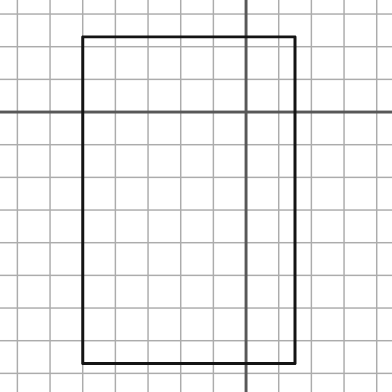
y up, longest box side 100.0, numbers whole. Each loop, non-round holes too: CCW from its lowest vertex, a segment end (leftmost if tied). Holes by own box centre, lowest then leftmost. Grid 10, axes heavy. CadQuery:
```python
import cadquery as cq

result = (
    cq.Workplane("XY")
    .moveTo(-50.0, -77.0)
    .lineTo(15.0, -77.0)
    .lineTo(15.0, 23.0)
    .lineTo(-50.0, 23.0)
    .close()
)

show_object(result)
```